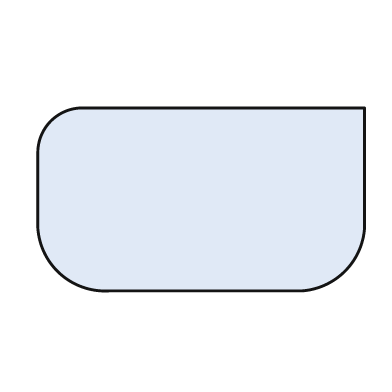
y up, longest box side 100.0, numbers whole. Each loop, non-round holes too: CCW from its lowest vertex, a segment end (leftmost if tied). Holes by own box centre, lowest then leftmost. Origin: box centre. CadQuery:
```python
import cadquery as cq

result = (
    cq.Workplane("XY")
    .moveTo(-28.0, -28.0)
    .lineTo(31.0, -28.0)
    .threePointArc((44.0, -22.0), (50.0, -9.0))
    .lineTo(50.0, 28.0)
    .lineTo(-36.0, 28.0)
    .threePointArc((-46.0, 24.0), (-50.0, 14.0))
    .lineTo(-50.0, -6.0)
    .threePointArc((-44.0, -22.0), (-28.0, -28.0))
    .close()
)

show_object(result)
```